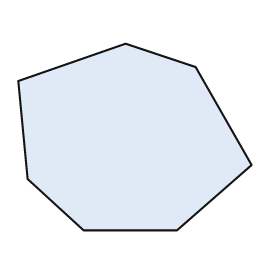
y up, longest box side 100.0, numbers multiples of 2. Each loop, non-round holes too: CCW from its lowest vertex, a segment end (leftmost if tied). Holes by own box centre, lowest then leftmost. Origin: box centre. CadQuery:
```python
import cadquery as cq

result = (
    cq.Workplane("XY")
    .moveTo(-22.0, -40.0)
    .lineTo(18.0, -40.0)
    .lineTo(50.0, -12.0)
    .lineTo(26.0, 30.0)
    .lineTo(-4.0, 40.0)
    .lineTo(-50.0, 24.0)
    .lineTo(-46.0, -18.0)
    .close()
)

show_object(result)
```